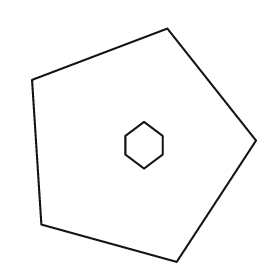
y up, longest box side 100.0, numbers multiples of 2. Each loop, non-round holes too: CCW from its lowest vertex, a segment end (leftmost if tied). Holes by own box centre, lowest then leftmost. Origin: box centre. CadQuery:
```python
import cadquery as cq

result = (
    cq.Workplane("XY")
    .moveTo(14.0, -50.0)
    .lineTo(48.0, 2.0)
    .lineTo(10.0, 50.0)
    .lineTo(-48.0, 28.0)
    .lineTo(-44.0, -34.0)
    .close()
    .moveTo(0.0, -10.0)
    .lineTo(8.0, -4.0)
    .lineTo(8.0, 4.0)
    .lineTo(0.0, 10.0)
    .lineTo(-8.0, 4.0)
    .lineTo(-8.0, -4.0)
    .close()
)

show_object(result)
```